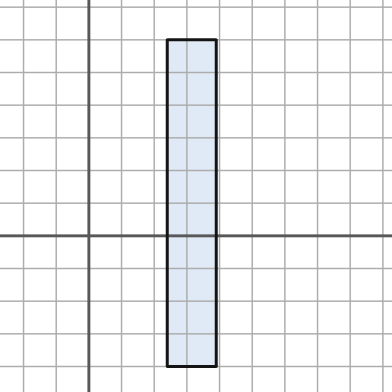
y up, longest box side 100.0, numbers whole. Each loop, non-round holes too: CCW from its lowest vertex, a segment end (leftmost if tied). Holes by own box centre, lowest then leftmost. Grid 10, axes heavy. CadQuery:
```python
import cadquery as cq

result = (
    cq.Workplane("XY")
    .moveTo(24.0, -40.0)
    .lineTo(39.0, -40.0)
    .lineTo(39.0, 60.0)
    .lineTo(24.0, 60.0)
    .close()
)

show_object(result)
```